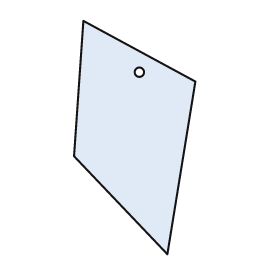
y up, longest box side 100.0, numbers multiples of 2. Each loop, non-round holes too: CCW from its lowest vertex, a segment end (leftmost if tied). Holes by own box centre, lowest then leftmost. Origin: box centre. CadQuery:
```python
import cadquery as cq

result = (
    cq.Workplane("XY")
    .moveTo(14.0, -50.0)
    .lineTo(26.0, 24.0)
    .lineTo(-22.0, 50.0)
    .lineTo(-26.0, -8.0)
    .close()
    .moveTo(2.0, 28.0)
    .circle(2.0)
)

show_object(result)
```